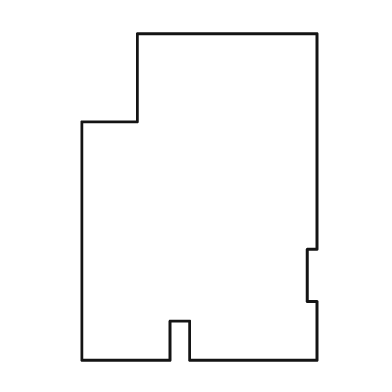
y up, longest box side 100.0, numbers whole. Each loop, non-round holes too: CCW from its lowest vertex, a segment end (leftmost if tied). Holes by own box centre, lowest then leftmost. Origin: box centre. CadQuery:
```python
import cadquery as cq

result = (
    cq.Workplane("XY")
    .moveTo(-36.0, -50.0)
    .lineTo(-9.0, -50.0)
    .lineTo(-9.0, -38.0)
    .lineTo(-3.0, -38.0)
    .lineTo(-3.0, -50.0)
    .lineTo(36.0, -50.0)
    .lineTo(36.0, -32.0)
    .lineTo(33.0, -32.0)
    .lineTo(33.0, -16.0)
    .lineTo(36.0, -16.0)
    .lineTo(36.0, 50.0)
    .lineTo(-19.0, 50.0)
    .lineTo(-19.0, 23.0)
    .lineTo(-36.0, 23.0)
    .close()
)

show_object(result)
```